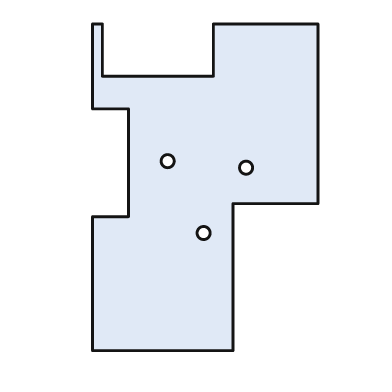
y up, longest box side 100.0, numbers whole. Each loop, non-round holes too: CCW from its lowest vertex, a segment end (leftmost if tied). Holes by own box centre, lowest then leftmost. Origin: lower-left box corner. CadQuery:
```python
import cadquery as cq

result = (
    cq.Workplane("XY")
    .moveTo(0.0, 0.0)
    .lineTo(43.0, 0.0)
    .lineTo(43.0, 45.0)
    .lineTo(69.0, 45.0)
    .lineTo(69.0, 100.0)
    .lineTo(37.0, 100.0)
    .lineTo(37.0, 84.0)
    .lineTo(3.0, 84.0)
    .lineTo(3.0, 100.0)
    .lineTo(0.0, 100.0)
    .lineTo(0.0, 74.0)
    .lineTo(11.0, 74.0)
    .lineTo(11.0, 41.0)
    .lineTo(0.0, 41.0)
    .close()
    .moveTo(34.0, 36.0)
    .circle(2.0)
    .moveTo(47.0, 56.0)
    .circle(2.0)
    .moveTo(23.0, 58.0)
    .circle(2.0)
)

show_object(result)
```